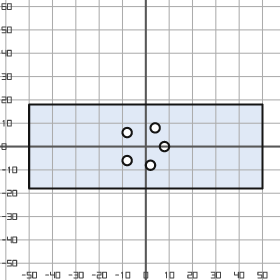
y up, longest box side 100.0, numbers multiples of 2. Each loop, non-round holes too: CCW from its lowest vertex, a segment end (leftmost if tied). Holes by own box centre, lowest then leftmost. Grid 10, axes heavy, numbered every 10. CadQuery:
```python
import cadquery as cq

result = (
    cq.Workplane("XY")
    .moveTo(-50.0, -18.0)
    .lineTo(50.0, -18.0)
    .lineTo(50.0, 18.0)
    .lineTo(-50.0, 18.0)
    .close()
    .moveTo(2.0, -8.0)
    .circle(2.0)
    .moveTo(-8.0, -6.0)
    .circle(2.0)
    .moveTo(8.0, 0.0)
    .circle(2.0)
    .moveTo(-8.0, 6.0)
    .circle(2.0)
    .moveTo(4.0, 8.0)
    .circle(2.0)
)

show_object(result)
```